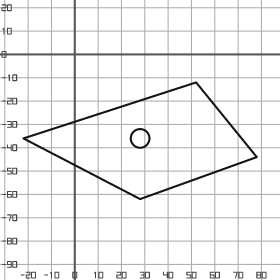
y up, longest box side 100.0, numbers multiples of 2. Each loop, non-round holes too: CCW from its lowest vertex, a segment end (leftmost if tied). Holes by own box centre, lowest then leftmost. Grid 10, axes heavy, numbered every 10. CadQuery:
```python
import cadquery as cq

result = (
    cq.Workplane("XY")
    .moveTo(28.0, -62.0)
    .lineTo(78.0, -44.0)
    .lineTo(52.0, -12.0)
    .lineTo(-22.0, -36.0)
    .close()
    .moveTo(28.0, -36.0)
    .circle(4.0)
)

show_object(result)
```